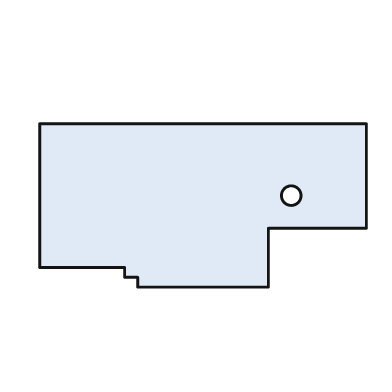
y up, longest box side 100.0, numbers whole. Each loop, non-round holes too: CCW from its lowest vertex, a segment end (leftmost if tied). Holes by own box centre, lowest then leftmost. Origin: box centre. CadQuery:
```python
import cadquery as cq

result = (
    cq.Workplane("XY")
    .moveTo(-20.0, -25.0)
    .lineTo(20.0, -25.0)
    .lineTo(20.0, -7.0)
    .lineTo(50.0, -7.0)
    .lineTo(50.0, 25.0)
    .lineTo(-50.0, 25.0)
    .lineTo(-50.0, -19.0)
    .lineTo(-24.0, -19.0)
    .lineTo(-24.0, -22.0)
    .lineTo(-20.0, -22.0)
    .close()
    .moveTo(27.0, 3.0)
    .circle(3.0)
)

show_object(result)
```